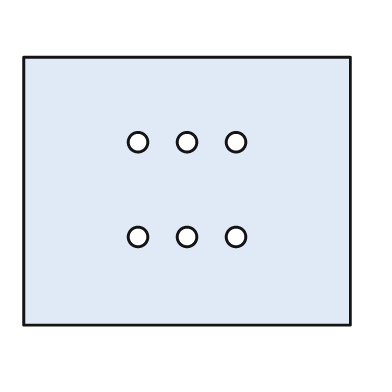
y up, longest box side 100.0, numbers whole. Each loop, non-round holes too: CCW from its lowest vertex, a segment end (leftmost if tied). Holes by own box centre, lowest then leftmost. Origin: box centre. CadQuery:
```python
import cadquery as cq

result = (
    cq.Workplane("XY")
    .moveTo(-50.0, -41.0)
    .lineTo(50.0, -41.0)
    .lineTo(50.0, 41.0)
    .lineTo(-50.0, 41.0)
    .close()
    .moveTo(-15.0, -14.0)
    .circle(3.0)
    .moveTo(0.0, -14.0)
    .circle(3.0)
    .moveTo(15.0, -14.0)
    .circle(3.0)
    .moveTo(-15.0, 15.0)
    .circle(3.0)
    .moveTo(0.0, 15.0)
    .circle(3.0)
    .moveTo(15.0, 15.0)
    .circle(3.0)
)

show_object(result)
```